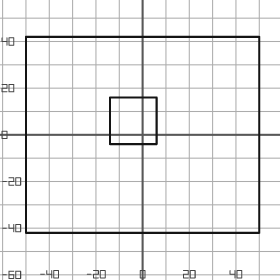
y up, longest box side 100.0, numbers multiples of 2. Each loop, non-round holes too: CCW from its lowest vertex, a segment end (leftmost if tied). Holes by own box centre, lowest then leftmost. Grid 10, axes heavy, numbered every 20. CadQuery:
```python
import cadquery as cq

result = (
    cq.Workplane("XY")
    .moveTo(-50.0, -42.0)
    .lineTo(50.0, -42.0)
    .lineTo(50.0, 42.0)
    .lineTo(-50.0, 42.0)
    .close()
    .moveTo(-14.0, -4.0)
    .lineTo(6.0, -4.0)
    .lineTo(6.0, 16.0)
    .lineTo(-14.0, 16.0)
    .close()
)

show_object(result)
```